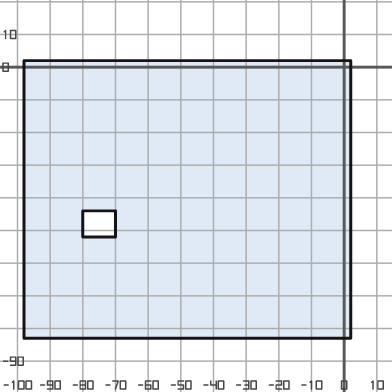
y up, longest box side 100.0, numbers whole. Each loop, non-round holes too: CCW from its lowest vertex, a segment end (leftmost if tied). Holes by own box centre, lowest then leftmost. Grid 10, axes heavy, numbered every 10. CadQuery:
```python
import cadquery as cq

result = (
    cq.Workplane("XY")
    .moveTo(-98.0, -83.0)
    .lineTo(2.0, -83.0)
    .lineTo(2.0, 2.0)
    .lineTo(-98.0, 2.0)
    .close()
    .moveTo(-80.0, -52.0)
    .lineTo(-70.0, -52.0)
    .lineTo(-70.0, -44.0)
    .lineTo(-80.0, -44.0)
    .close()
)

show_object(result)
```